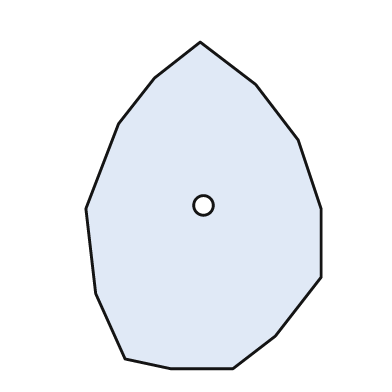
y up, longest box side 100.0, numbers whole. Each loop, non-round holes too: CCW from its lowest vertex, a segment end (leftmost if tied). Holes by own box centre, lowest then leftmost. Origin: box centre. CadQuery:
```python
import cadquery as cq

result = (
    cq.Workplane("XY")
    .moveTo(-10.0, -50.0)
    .lineTo(9.0, -50.0)
    .lineTo(22.0, -40.0)
    .lineTo(36.0, -22.0)
    .lineTo(36.0, -1.0)
    .lineTo(29.0, 20.0)
    .lineTo(16.0, 37.0)
    .lineTo(-1.0, 50.0)
    .lineTo(-15.0, 39.0)
    .lineTo(-26.0, 25.0)
    .lineTo(-36.0, -1.0)
    .lineTo(-33.0, -27.0)
    .lineTo(-24.0, -47.0)
    .close()
    .moveTo(0.0, 0.0)
    .circle(3.0)
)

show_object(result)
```